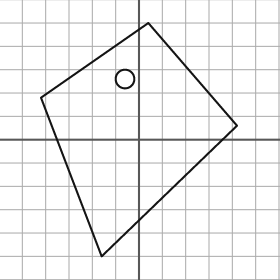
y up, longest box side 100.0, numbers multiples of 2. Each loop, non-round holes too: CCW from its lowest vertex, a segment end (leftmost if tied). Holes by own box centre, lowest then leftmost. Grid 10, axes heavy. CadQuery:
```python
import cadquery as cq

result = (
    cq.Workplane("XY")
    .moveTo(-16.0, -50.0)
    .lineTo(42.0, 6.0)
    .lineTo(4.0, 50.0)
    .lineTo(-42.0, 18.0)
    .close()
    .moveTo(-6.0, 26.0)
    .circle(4.0)
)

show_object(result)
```